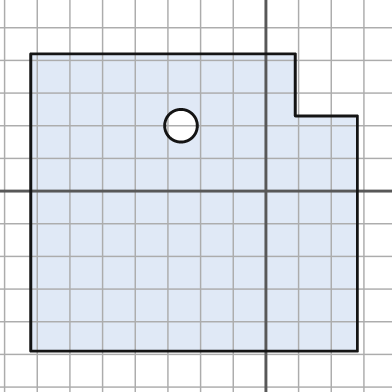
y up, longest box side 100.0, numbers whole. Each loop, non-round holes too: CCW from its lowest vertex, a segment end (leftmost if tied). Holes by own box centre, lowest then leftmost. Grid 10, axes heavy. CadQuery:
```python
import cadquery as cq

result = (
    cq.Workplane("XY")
    .moveTo(-72.0, -49.0)
    .lineTo(28.0, -49.0)
    .lineTo(28.0, 23.0)
    .lineTo(9.0, 23.0)
    .lineTo(9.0, 42.0)
    .lineTo(-72.0, 42.0)
    .close()
    .moveTo(-26.0, 20.0)
    .circle(5.0)
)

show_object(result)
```